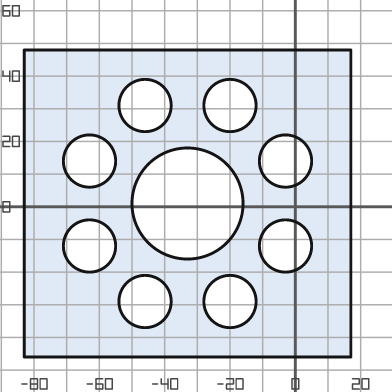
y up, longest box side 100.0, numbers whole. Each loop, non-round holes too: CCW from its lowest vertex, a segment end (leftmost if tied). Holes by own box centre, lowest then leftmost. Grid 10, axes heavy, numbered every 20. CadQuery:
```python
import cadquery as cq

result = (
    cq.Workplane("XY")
    .moveTo(-83.0, -46.0)
    .lineTo(17.0, -46.0)
    .lineTo(17.0, 48.0)
    .lineTo(-83.0, 48.0)
    .close()
    .moveTo(-46.0, -29.0)
    .circle(8.0)
    .moveTo(-20.0, -29.0)
    .circle(8.0)
    .moveTo(-63.0, -12.0)
    .circle(8.0)
    .moveTo(-3.0, -12.0)
    .circle(8.0)
    .moveTo(-33.0, 1.0)
    .circle(17.0)
    .moveTo(-63.0, 14.0)
    .circle(8.0)
    .moveTo(-3.0, 14.0)
    .circle(8.0)
    .moveTo(-46.0, 31.0)
    .circle(8.0)
    .moveTo(-20.0, 31.0)
    .circle(8.0)
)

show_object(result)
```